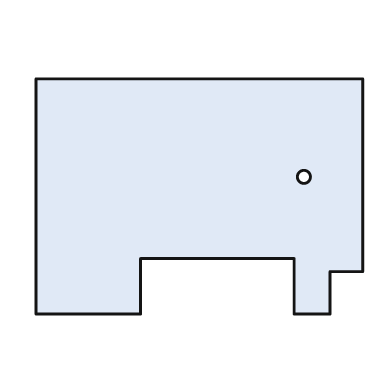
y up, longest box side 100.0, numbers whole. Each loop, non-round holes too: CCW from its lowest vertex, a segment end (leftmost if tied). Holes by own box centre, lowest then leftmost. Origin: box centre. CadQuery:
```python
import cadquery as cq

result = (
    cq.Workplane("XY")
    .moveTo(-50.0, -36.0)
    .lineTo(-18.0, -36.0)
    .lineTo(-18.0, -19.0)
    .lineTo(29.0, -19.0)
    .lineTo(29.0, -36.0)
    .lineTo(40.0, -36.0)
    .lineTo(40.0, -23.0)
    .lineTo(50.0, -23.0)
    .lineTo(50.0, 36.0)
    .lineTo(-50.0, 36.0)
    .close()
    .moveTo(32.0, 6.0)
    .circle(2.0)
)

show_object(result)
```